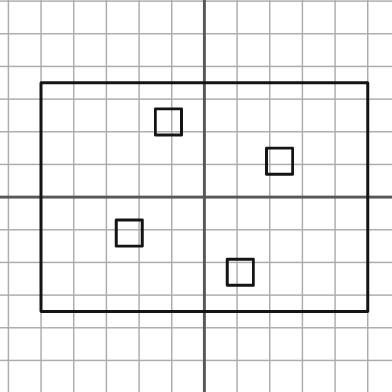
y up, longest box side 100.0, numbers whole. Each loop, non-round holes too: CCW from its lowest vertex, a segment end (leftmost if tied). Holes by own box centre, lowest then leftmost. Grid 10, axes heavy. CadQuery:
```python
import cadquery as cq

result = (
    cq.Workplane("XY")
    .moveTo(-50.0, -35.0)
    .lineTo(50.0, -35.0)
    .lineTo(50.0, 35.0)
    .lineTo(-50.0, 35.0)
    .close()
    .moveTo(7.0, -27.0)
    .lineTo(15.0, -27.0)
    .lineTo(15.0, -19.0)
    .lineTo(7.0, -19.0)
    .close()
    .moveTo(-27.0, -15.0)
    .lineTo(-19.0, -15.0)
    .lineTo(-19.0, -7.0)
    .lineTo(-27.0, -7.0)
    .close()
    .moveTo(19.0, 7.0)
    .lineTo(27.0, 7.0)
    .lineTo(27.0, 15.0)
    .lineTo(19.0, 15.0)
    .close()
    .moveTo(-15.0, 19.0)
    .lineTo(-7.0, 19.0)
    .lineTo(-7.0, 27.0)
    .lineTo(-15.0, 27.0)
    .close()
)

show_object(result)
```